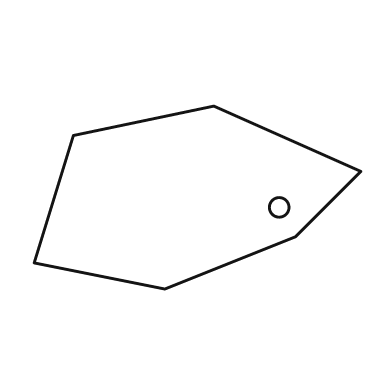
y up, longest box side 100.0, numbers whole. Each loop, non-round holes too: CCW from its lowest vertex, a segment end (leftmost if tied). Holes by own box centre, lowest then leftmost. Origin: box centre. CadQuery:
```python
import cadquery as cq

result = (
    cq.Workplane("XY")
    .moveTo(-10.0, -28.0)
    .lineTo(30.0, -12.0)
    .lineTo(50.0, 8.0)
    .lineTo(5.0, 28.0)
    .lineTo(-38.0, 19.0)
    .lineTo(-50.0, -20.0)
    .close()
    .moveTo(25.0, -3.0)
    .circle(3.0)
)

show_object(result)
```